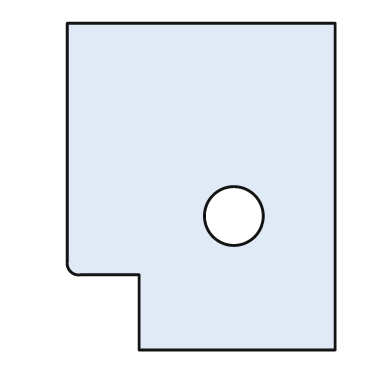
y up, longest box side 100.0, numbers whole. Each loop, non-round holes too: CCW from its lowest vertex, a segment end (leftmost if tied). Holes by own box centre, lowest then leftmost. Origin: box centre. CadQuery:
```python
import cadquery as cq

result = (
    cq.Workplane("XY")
    .moveTo(-19.0, -50.0)
    .lineTo(41.0, -50.0)
    .lineTo(41.0, 50.0)
    .lineTo(-41.0, 50.0)
    .lineTo(-41.0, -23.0)
    .threePointArc((-40.0, -26.0), (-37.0, -27.0))
    .lineTo(-19.0, -27.0)
    .close()
    .moveTo(10.0, -9.0)
    .circle(9.0)
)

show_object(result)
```